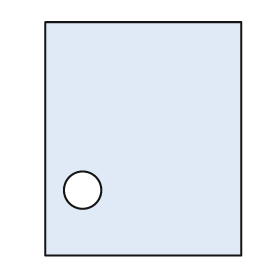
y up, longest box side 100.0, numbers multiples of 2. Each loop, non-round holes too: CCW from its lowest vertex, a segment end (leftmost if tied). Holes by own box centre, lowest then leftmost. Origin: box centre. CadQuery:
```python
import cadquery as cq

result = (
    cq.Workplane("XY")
    .moveTo(-42.0, -50.0)
    .lineTo(42.0, -50.0)
    .lineTo(42.0, 50.0)
    .lineTo(-42.0, 50.0)
    .close()
    .moveTo(-26.0, -22.0)
    .circle(8.0)
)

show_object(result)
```